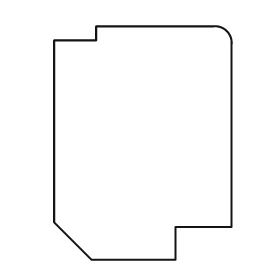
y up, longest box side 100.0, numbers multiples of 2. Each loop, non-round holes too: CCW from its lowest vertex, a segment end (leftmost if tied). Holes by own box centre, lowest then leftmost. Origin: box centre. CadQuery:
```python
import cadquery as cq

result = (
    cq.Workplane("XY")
    .moveTo(-22.0, -50.0)
    .lineTo(14.0, -50.0)
    .lineTo(14.0, -36.0)
    .lineTo(38.0, -36.0)
    .lineTo(38.0, 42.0)
    .threePointArc((36.0, 48.0), (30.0, 50.0))
    .lineTo(-20.0, 50.0)
    .lineTo(-20.0, 44.0)
    .lineTo(-38.0, 44.0)
    .lineTo(-38.0, -34.0)
    .close()
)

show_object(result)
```